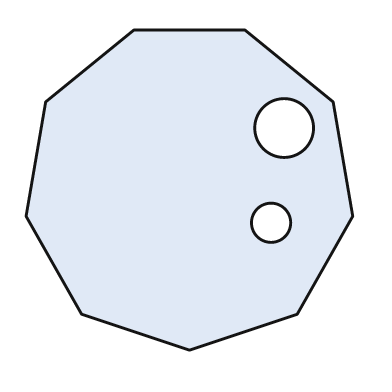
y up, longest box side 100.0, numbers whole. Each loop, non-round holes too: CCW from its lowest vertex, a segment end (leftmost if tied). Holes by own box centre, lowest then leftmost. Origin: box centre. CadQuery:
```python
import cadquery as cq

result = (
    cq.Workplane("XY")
    .moveTo(0.0, -49.0)
    .lineTo(33.0, -38.0)
    .lineTo(50.0, -8.0)
    .lineTo(44.0, 27.0)
    .lineTo(17.0, 49.0)
    .lineTo(-17.0, 49.0)
    .lineTo(-44.0, 27.0)
    .lineTo(-50.0, -8.0)
    .lineTo(-33.0, -38.0)
    .close()
    .moveTo(25.0, -10.0)
    .circle(6.0)
    .moveTo(29.0, 19.0)
    .circle(9.0)
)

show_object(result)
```